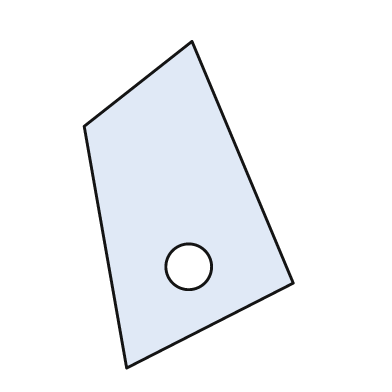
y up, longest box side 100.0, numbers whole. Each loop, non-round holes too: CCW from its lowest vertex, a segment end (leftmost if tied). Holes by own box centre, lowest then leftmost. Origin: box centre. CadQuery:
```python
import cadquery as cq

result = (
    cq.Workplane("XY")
    .moveTo(-19.0, -50.0)
    .lineTo(32.0, -24.0)
    .lineTo(1.0, 50.0)
    .lineTo(-32.0, 24.0)
    .close()
    .moveTo(0.0, -19.0)
    .circle(7.0)
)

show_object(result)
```